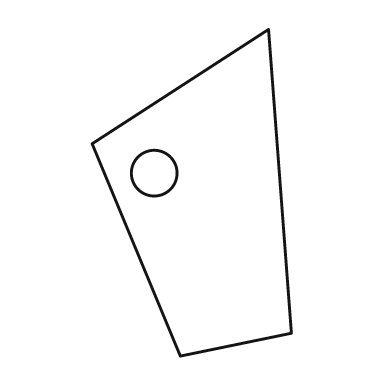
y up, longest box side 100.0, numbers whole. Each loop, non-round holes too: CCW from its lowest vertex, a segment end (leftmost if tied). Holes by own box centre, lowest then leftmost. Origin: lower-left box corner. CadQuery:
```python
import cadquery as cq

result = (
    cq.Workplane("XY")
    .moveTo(27.0, 0.0)
    .lineTo(61.0, 7.0)
    .lineTo(54.0, 100.0)
    .lineTo(0.0, 65.0)
    .close()
    .moveTo(19.0, 56.0)
    .circle(7.0)
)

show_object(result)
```